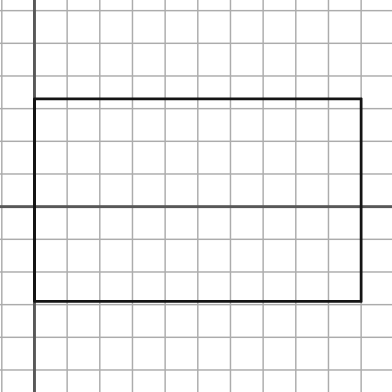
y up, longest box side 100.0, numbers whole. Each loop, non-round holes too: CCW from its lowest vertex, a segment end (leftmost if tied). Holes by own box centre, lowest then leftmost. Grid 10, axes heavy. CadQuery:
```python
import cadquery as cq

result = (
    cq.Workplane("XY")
    .moveTo(0.0, -29.0)
    .lineTo(100.0, -29.0)
    .lineTo(100.0, 33.0)
    .lineTo(0.0, 33.0)
    .close()
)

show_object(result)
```